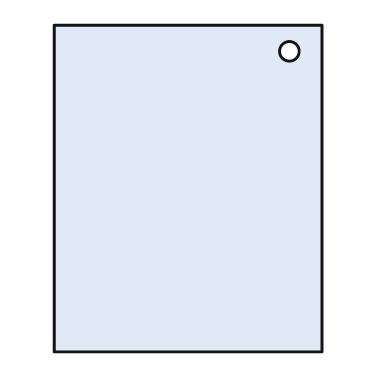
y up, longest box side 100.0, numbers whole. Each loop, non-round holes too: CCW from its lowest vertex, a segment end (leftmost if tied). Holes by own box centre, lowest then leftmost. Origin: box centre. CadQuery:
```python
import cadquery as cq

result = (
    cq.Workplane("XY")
    .moveTo(-41.0, -50.0)
    .lineTo(41.0, -50.0)
    .lineTo(41.0, 50.0)
    .lineTo(-41.0, 50.0)
    .close()
    .moveTo(31.0, 42.0)
    .circle(3.0)
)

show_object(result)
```